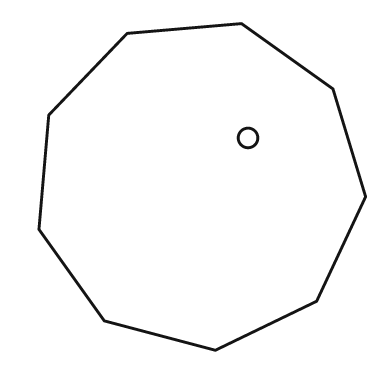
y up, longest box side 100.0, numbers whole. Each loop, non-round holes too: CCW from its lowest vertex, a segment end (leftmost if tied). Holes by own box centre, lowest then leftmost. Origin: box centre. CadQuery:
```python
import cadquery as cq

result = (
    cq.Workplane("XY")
    .moveTo(4.0, -50.0)
    .lineTo(35.0, -35.0)
    .lineTo(50.0, -3.0)
    .lineTo(40.0, 30.0)
    .lineTo(12.0, 50.0)
    .lineTo(-23.0, 47.0)
    .lineTo(-47.0, 22.0)
    .lineTo(-50.0, -13.0)
    .lineTo(-30.0, -41.0)
    .close()
    .moveTo(14.0, 15.0)
    .circle(3.0)
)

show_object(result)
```